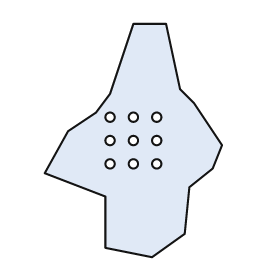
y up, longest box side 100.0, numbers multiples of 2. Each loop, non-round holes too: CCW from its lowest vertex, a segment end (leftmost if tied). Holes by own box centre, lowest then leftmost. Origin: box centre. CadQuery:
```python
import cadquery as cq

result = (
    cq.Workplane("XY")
    .moveTo(8.0, -50.0)
    .lineTo(22.0, -40.0)
    .lineTo(24.0, -20.0)
    .lineTo(34.0, -12.0)
    .lineTo(38.0, -2.0)
    .lineTo(26.0, 16.0)
    .lineTo(20.0, 22.0)
    .lineTo(14.0, 50.0)
    .lineTo(0.0, 50.0)
    .lineTo(-10.0, 20.0)
    .lineTo(-16.0, 12.0)
    .lineTo(-28.0, 4.0)
    .lineTo(-38.0, -14.0)
    .lineTo(-12.0, -24.0)
    .lineTo(-12.0, -46.0)
    .close()
    .moveTo(-10.0, -10.0)
    .circle(2.0)
    .moveTo(0.0, -10.0)
    .circle(2.0)
    .moveTo(10.0, -10.0)
    .circle(2.0)
    .moveTo(-10.0, 0.0)
    .circle(2.0)
    .moveTo(0.0, 0.0)
    .circle(2.0)
    .moveTo(10.0, 0.0)
    .circle(2.0)
    .moveTo(-10.0, 10.0)
    .circle(2.0)
    .moveTo(0.0, 10.0)
    .circle(2.0)
    .moveTo(10.0, 10.0)
    .circle(2.0)
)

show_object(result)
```